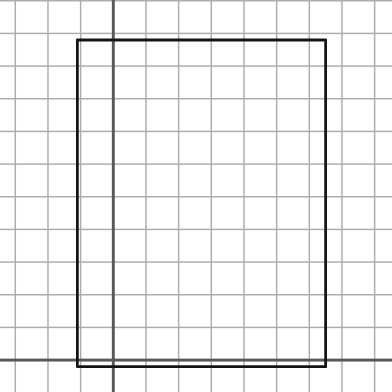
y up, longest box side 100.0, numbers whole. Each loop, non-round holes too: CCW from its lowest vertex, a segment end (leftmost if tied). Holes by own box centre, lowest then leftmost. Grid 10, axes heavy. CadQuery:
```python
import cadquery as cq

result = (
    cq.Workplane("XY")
    .moveTo(-11.0, -2.0)
    .lineTo(65.0, -2.0)
    .lineTo(65.0, 98.0)
    .lineTo(-11.0, 98.0)
    .close()
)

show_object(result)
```